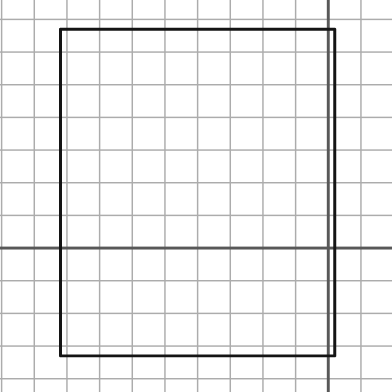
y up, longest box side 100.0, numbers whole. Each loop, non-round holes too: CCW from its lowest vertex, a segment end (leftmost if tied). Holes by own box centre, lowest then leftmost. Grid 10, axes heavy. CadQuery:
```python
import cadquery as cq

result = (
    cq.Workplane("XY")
    .moveTo(-82.0, -33.0)
    .lineTo(2.0, -33.0)
    .lineTo(2.0, 67.0)
    .lineTo(-82.0, 67.0)
    .close()
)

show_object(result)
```